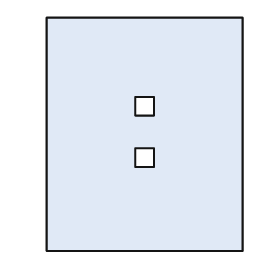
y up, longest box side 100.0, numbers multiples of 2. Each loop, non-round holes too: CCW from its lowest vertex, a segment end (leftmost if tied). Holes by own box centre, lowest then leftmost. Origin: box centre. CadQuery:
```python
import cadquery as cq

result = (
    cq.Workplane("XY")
    .moveTo(-42.0, -50.0)
    .lineTo(42.0, -50.0)
    .lineTo(42.0, 50.0)
    .lineTo(-42.0, 50.0)
    .close()
    .moveTo(-4.0, -14.0)
    .lineTo(4.0, -14.0)
    .lineTo(4.0, -6.0)
    .lineTo(-4.0, -6.0)
    .close()
    .moveTo(-4.0, 8.0)
    .lineTo(4.0, 8.0)
    .lineTo(4.0, 16.0)
    .lineTo(-4.0, 16.0)
    .close()
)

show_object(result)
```